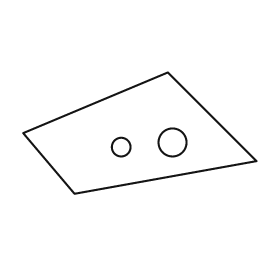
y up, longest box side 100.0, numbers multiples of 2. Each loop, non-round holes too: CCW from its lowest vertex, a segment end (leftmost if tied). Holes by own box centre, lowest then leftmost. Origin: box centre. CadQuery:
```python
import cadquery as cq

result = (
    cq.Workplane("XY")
    .moveTo(-28.0, -26.0)
    .lineTo(50.0, -12.0)
    .lineTo(12.0, 26.0)
    .lineTo(-50.0, 0.0)
    .close()
    .moveTo(-8.0, -6.0)
    .circle(4.0)
    .moveTo(14.0, -4.0)
    .circle(6.0)
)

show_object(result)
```